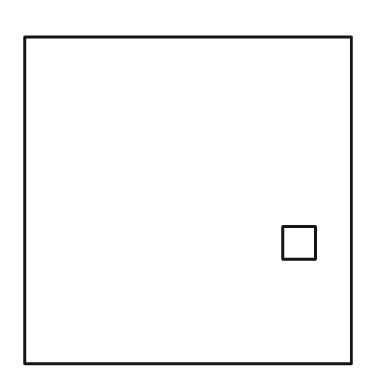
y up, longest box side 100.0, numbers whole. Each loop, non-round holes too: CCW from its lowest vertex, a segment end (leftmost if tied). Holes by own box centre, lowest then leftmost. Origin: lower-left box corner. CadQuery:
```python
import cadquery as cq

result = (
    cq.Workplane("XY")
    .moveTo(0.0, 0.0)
    .lineTo(100.0, 0.0)
    .lineTo(100.0, 100.0)
    .lineTo(0.0, 100.0)
    .close()
    .moveTo(79.0, 32.0)
    .lineTo(89.0, 32.0)
    .lineTo(89.0, 42.0)
    .lineTo(79.0, 42.0)
    .close()
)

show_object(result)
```